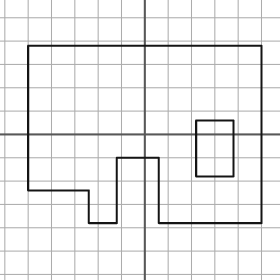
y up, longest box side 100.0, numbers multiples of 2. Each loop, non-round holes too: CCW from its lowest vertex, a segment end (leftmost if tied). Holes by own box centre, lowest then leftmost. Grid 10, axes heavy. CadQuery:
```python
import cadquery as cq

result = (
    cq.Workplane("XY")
    .moveTo(-24.0, -38.0)
    .lineTo(-12.0, -38.0)
    .lineTo(-12.0, -10.0)
    .lineTo(6.0, -10.0)
    .lineTo(6.0, -38.0)
    .lineTo(50.0, -38.0)
    .lineTo(50.0, 38.0)
    .lineTo(-50.0, 38.0)
    .lineTo(-50.0, -24.0)
    .lineTo(-24.0, -24.0)
    .close()
    .moveTo(22.0, -18.0)
    .lineTo(38.0, -18.0)
    .lineTo(38.0, 6.0)
    .lineTo(22.0, 6.0)
    .close()
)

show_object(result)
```